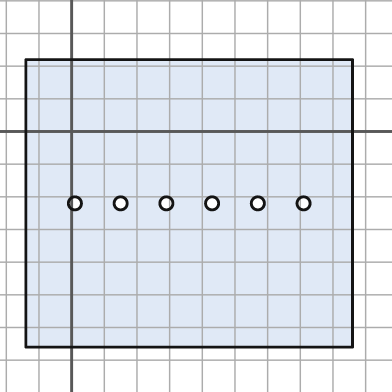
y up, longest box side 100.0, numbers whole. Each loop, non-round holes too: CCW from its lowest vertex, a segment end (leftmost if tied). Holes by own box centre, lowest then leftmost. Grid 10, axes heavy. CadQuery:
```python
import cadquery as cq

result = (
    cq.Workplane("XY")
    .moveTo(-14.0, -66.0)
    .lineTo(86.0, -66.0)
    .lineTo(86.0, 22.0)
    .lineTo(-14.0, 22.0)
    .close()
    .moveTo(1.0, -22.0)
    .circle(2.0)
    .moveTo(15.0, -22.0)
    .circle(2.0)
    .moveTo(29.0, -22.0)
    .circle(2.0)
    .moveTo(43.0, -22.0)
    .circle(2.0)
    .moveTo(57.0, -22.0)
    .circle(2.0)
    .moveTo(71.0, -22.0)
    .circle(2.0)
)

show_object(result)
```